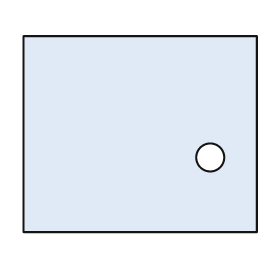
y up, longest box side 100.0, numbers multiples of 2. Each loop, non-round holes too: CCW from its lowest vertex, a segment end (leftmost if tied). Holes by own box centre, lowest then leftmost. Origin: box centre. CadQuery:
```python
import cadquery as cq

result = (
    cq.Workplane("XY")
    .moveTo(-50.0, -42.0)
    .lineTo(50.0, -42.0)
    .lineTo(50.0, 42.0)
    .lineTo(-50.0, 42.0)
    .close()
    .moveTo(30.0, -10.0)
    .circle(6.0)
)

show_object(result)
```